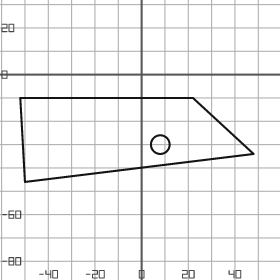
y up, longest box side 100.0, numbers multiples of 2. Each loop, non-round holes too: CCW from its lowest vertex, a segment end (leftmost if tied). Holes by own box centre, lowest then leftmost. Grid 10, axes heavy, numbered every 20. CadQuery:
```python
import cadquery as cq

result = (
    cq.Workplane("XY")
    .moveTo(-50.0, -46.0)
    .lineTo(48.0, -34.0)
    .lineTo(22.0, -10.0)
    .lineTo(-52.0, -10.0)
    .close()
    .moveTo(8.0, -30.0)
    .circle(4.0)
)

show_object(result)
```